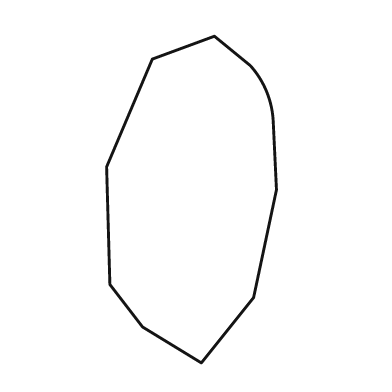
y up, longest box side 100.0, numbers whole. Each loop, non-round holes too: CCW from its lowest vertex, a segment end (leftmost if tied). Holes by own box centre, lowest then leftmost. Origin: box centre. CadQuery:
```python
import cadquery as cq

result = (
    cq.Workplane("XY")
    .moveTo(3.0, -50.0)
    .lineTo(19.0, -30.0)
    .lineTo(26.0, 3.0)
    .lineTo(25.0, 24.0)
    .threePointArc((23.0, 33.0), (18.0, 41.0))
    .lineTo(7.0, 50.0)
    .lineTo(-12.0, 43.0)
    .lineTo(-26.0, 10.0)
    .lineTo(-25.0, -26.0)
    .lineTo(-15.0, -39.0)
    .close()
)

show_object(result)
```